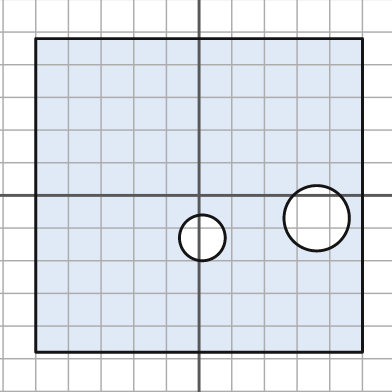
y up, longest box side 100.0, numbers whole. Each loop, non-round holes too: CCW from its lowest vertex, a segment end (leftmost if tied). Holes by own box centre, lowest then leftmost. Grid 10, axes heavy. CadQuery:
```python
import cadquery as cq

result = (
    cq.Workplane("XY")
    .moveTo(-50.0, -48.0)
    .lineTo(50.0, -48.0)
    .lineTo(50.0, 48.0)
    .lineTo(-50.0, 48.0)
    .close()
    .moveTo(1.0, -13.0)
    .circle(7.0)
    .moveTo(36.0, -7.0)
    .circle(10.0)
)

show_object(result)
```